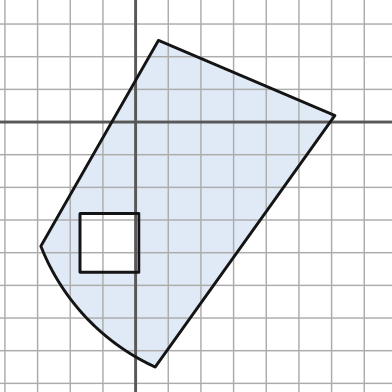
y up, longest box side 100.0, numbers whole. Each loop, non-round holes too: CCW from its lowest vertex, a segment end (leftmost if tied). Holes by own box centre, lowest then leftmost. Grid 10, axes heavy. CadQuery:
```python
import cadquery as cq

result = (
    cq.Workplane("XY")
    .moveTo(6.0, -75.0)
    .lineTo(61.0, 2.0)
    .lineTo(7.0, 25.0)
    .lineTo(-29.0, -38.0)
    .threePointArc((-15.0, -60.0), (6.0, -75.0))
    .close()
    .moveTo(-17.0, -46.0)
    .lineTo(1.0, -46.0)
    .lineTo(1.0, -28.0)
    .lineTo(-17.0, -28.0)
    .close()
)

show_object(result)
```